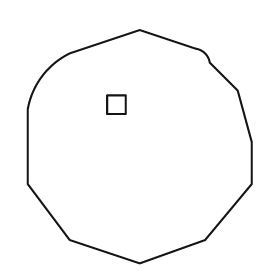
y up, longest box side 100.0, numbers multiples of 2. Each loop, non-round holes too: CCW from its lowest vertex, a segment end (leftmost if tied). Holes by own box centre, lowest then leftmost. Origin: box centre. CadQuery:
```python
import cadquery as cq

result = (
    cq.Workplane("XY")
    .moveTo(0.0, -50.0)
    .lineTo(28.0, -40.0)
    .lineTo(48.0, -16.0)
    .lineTo(48.0, 2.0)
    .lineTo(42.0, 24.0)
    .lineTo(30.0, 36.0)
    .threePointArc((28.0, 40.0), (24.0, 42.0))
    .lineTo(0.0, 50.0)
    .lineTo(-30.0, 40.0)
    .threePointArc((-42.0, 30.0), (-48.0, 16.0))
    .lineTo(-48.0, -16.0)
    .lineTo(-30.0, -40.0)
    .close()
    .moveTo(-14.0, 14.0)
    .lineTo(-6.0, 14.0)
    .lineTo(-6.0, 22.0)
    .lineTo(-14.0, 22.0)
    .close()
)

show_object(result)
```